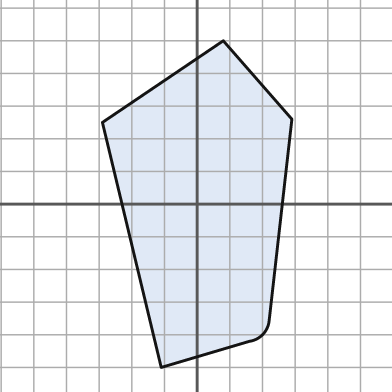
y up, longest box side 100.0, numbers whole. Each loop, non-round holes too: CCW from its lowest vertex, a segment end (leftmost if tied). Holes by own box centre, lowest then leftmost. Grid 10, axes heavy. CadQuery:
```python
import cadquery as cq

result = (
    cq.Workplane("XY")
    .moveTo(-11.0, -50.0)
    .lineTo(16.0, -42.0)
    .threePointArc((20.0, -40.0), (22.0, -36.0))
    .lineTo(29.0, 26.0)
    .lineTo(8.0, 50.0)
    .lineTo(-29.0, 25.0)
    .close()
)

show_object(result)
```